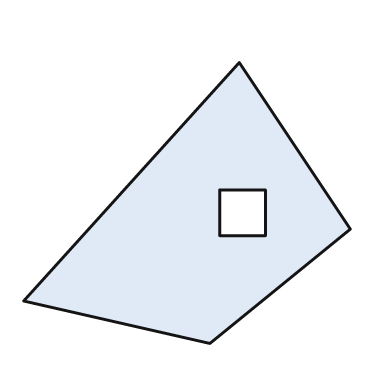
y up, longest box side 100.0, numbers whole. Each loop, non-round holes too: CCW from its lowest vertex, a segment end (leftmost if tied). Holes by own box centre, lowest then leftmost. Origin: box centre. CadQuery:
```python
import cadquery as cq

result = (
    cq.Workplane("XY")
    .moveTo(7.0, -43.0)
    .lineTo(50.0, -8.0)
    .lineTo(16.0, 43.0)
    .lineTo(-50.0, -30.0)
    .close()
    .moveTo(10.0, -10.0)
    .lineTo(24.0, -10.0)
    .lineTo(24.0, 4.0)
    .lineTo(10.0, 4.0)
    .close()
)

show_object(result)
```